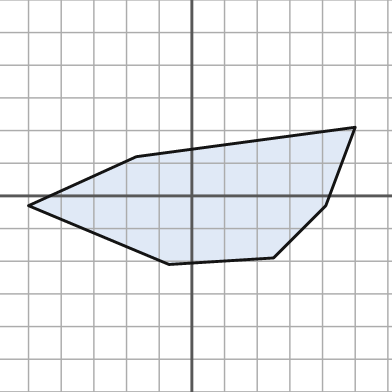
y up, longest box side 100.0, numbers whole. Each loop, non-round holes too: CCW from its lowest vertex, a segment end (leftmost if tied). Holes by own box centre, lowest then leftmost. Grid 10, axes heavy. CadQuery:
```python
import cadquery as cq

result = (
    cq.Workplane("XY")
    .moveTo(-7.0, -21.0)
    .lineTo(25.0, -19.0)
    .lineTo(41.0, -3.0)
    .lineTo(50.0, 21.0)
    .lineTo(-17.0, 12.0)
    .lineTo(-50.0, -3.0)
    .close()
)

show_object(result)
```